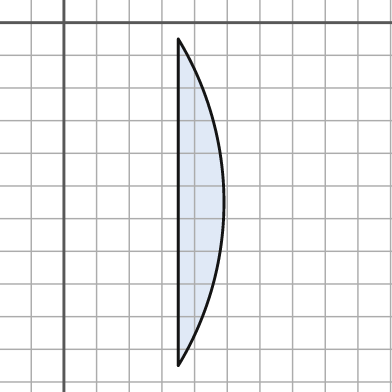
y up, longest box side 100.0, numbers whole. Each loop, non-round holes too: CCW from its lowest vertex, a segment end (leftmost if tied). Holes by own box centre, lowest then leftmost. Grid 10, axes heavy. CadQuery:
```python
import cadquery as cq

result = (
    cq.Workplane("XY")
    .moveTo(35.0, -105.0)
    .threePointArc((49.0, -55.0), (35.0, -5.0))
    .close()
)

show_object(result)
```